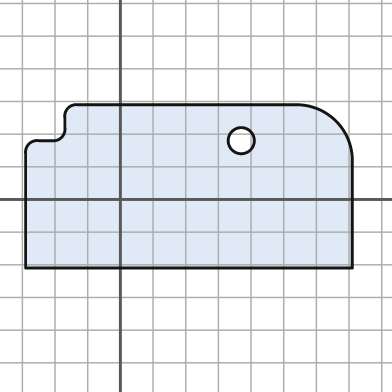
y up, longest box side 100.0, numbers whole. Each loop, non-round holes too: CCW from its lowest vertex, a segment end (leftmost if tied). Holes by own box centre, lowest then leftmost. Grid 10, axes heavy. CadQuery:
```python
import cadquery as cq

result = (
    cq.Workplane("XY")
    .moveTo(-29.0, -21.0)
    .lineTo(71.0, -21.0)
    .lineTo(71.0, 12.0)
    .threePointArc((66.0, 24.0), (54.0, 29.0))
    .lineTo(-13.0, 29.0)
    .threePointArc((-16.0, 28.0), (-17.0, 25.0))
    .lineTo(-17.0, 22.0)
    .threePointArc((-18.0, 19.0), (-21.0, 18.0))
    .lineTo(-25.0, 18.0)
    .threePointArc((-28.0, 17.0), (-29.0, 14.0))
    .close()
    .moveTo(37.0, 18.0)
    .circle(4.0)
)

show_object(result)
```